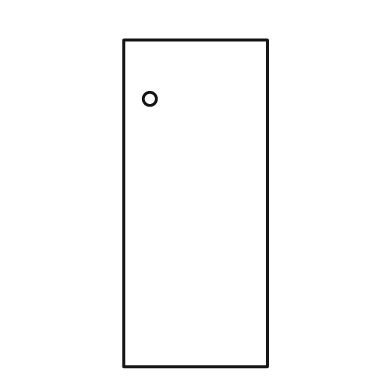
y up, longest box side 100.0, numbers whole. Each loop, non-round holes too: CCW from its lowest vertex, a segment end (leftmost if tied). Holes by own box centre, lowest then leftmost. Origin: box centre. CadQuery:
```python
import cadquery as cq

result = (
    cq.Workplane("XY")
    .moveTo(-22.0, -50.0)
    .lineTo(22.0, -50.0)
    .lineTo(22.0, 50.0)
    .lineTo(-22.0, 50.0)
    .close()
    .moveTo(-14.0, 32.0)
    .circle(2.0)
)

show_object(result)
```